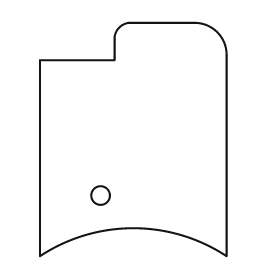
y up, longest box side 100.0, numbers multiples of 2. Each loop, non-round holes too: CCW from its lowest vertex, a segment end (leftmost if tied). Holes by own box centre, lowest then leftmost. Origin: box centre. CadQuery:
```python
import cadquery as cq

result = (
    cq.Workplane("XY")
    .moveTo(-40.0, -50.0)
    .threePointArc((0.0, -38.0), (40.0, -50.0))
    .lineTo(40.0, 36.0)
    .threePointArc((36.0, 46.0), (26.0, 50.0))
    .lineTo(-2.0, 50.0)
    .threePointArc((-6.0, 48.0), (-8.0, 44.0))
    .lineTo(-8.0, 34.0)
    .lineTo(-40.0, 34.0)
    .close()
    .moveTo(-14.0, -24.0)
    .circle(4.0)
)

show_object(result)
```